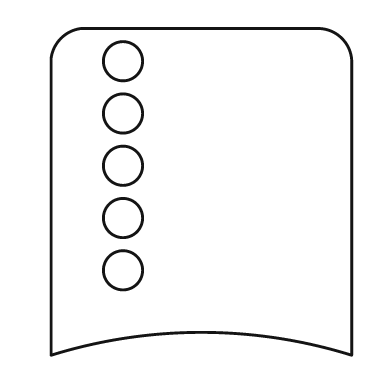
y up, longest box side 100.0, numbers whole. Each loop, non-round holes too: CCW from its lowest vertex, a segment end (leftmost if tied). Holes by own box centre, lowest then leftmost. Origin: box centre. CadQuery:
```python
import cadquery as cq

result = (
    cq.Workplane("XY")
    .moveTo(-46.0, -50.0)
    .threePointArc((0.0, -43.0), (46.0, -50.0))
    .lineTo(46.0, 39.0)
    .threePointArc((43.0, 47.0), (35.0, 50.0))
    .lineTo(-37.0, 50.0)
    .threePointArc((-43.0, 47.0), (-46.0, 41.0))
    .close()
    .moveTo(-24.0, -24.0)
    .circle(6.0)
    .moveTo(-24.0, -8.0)
    .circle(6.0)
    .moveTo(-24.0, 8.0)
    .circle(6.0)
    .moveTo(-24.0, 24.0)
    .circle(6.0)
    .moveTo(-24.0, 40.0)
    .circle(6.0)
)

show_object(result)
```